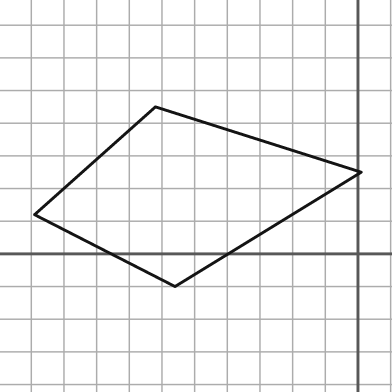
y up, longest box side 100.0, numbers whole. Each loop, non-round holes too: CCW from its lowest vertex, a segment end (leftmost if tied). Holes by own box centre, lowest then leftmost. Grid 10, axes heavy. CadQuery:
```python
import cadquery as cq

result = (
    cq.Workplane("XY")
    .moveTo(-56.0, -10.0)
    .lineTo(1.0, 25.0)
    .lineTo(-62.0, 45.0)
    .lineTo(-99.0, 12.0)
    .close()
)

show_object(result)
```